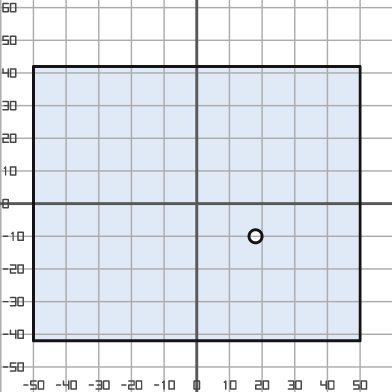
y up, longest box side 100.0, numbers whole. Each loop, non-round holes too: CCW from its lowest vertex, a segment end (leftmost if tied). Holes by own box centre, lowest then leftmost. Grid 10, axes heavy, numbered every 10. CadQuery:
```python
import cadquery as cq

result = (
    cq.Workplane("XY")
    .moveTo(-50.0, -42.0)
    .lineTo(50.0, -42.0)
    .lineTo(50.0, 42.0)
    .lineTo(-50.0, 42.0)
    .close()
    .moveTo(18.0, -10.0)
    .circle(2.0)
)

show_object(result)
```